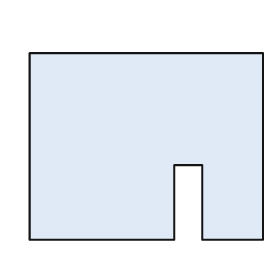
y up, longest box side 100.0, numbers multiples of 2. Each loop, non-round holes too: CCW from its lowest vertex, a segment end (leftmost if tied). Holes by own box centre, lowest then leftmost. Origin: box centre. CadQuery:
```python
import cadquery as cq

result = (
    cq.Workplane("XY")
    .moveTo(-50.0, -40.0)
    .lineTo(12.0, -40.0)
    .lineTo(12.0, -8.0)
    .lineTo(24.0, -8.0)
    .lineTo(24.0, -40.0)
    .lineTo(50.0, -40.0)
    .lineTo(50.0, 40.0)
    .lineTo(-50.0, 40.0)
    .close()
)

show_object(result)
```